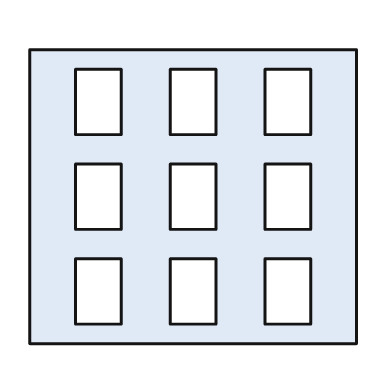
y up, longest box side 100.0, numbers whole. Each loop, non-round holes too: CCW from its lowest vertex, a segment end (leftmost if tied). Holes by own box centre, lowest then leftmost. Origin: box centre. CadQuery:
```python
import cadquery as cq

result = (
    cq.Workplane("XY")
    .moveTo(-50.0, -45.0)
    .lineTo(50.0, -45.0)
    .lineTo(50.0, 45.0)
    .lineTo(-50.0, 45.0)
    .close()
    .moveTo(-36.0, -39.0)
    .lineTo(-22.0, -39.0)
    .lineTo(-22.0, -19.0)
    .lineTo(-36.0, -19.0)
    .close()
    .moveTo(-7.0, -39.0)
    .lineTo(7.0, -39.0)
    .lineTo(7.0, -19.0)
    .lineTo(-7.0, -19.0)
    .close()
    .moveTo(22.0, -39.0)
    .lineTo(36.0, -39.0)
    .lineTo(36.0, -19.0)
    .lineTo(22.0, -19.0)
    .close()
    .moveTo(-36.0, -10.0)
    .lineTo(-22.0, -10.0)
    .lineTo(-22.0, 10.0)
    .lineTo(-36.0, 10.0)
    .close()
    .moveTo(-7.0, -10.0)
    .lineTo(7.0, -10.0)
    .lineTo(7.0, 10.0)
    .lineTo(-7.0, 10.0)
    .close()
    .moveTo(22.0, -10.0)
    .lineTo(36.0, -10.0)
    .lineTo(36.0, 10.0)
    .lineTo(22.0, 10.0)
    .close()
    .moveTo(-36.0, 19.0)
    .lineTo(-22.0, 19.0)
    .lineTo(-22.0, 39.0)
    .lineTo(-36.0, 39.0)
    .close()
    .moveTo(-7.0, 19.0)
    .lineTo(7.0, 19.0)
    .lineTo(7.0, 39.0)
    .lineTo(-7.0, 39.0)
    .close()
    .moveTo(22.0, 19.0)
    .lineTo(36.0, 19.0)
    .lineTo(36.0, 39.0)
    .lineTo(22.0, 39.0)
    .close()
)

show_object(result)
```